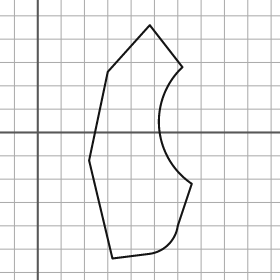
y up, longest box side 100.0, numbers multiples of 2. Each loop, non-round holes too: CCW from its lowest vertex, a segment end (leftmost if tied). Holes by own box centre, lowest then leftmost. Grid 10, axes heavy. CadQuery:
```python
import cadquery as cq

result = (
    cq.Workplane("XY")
    .moveTo(32.0, -54.0)
    .lineTo(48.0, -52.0)
    .threePointArc((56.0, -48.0), (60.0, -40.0))
    .lineTo(66.0, -22.0)
    .threePointArc((52.0, 2.0), (62.0, 28.0))
    .lineTo(48.0, 46.0)
    .lineTo(30.0, 26.0)
    .lineTo(22.0, -12.0)
    .close()
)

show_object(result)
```